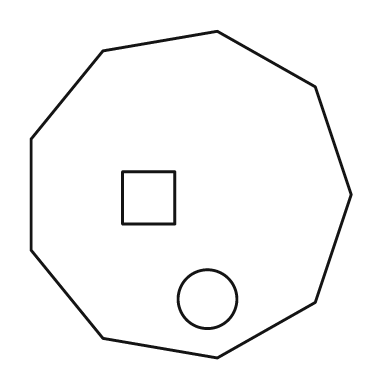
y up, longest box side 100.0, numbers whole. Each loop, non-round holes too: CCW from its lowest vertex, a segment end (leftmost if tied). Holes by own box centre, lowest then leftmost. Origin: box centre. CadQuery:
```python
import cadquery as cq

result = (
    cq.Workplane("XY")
    .moveTo(8.0, -50.0)
    .lineTo(38.0, -33.0)
    .lineTo(49.0, 0.0)
    .lineTo(38.0, 33.0)
    .lineTo(8.0, 50.0)
    .lineTo(-27.0, 44.0)
    .lineTo(-49.0, 17.0)
    .lineTo(-49.0, -17.0)
    .lineTo(-27.0, -44.0)
    .close()
    .moveTo(5.0, -32.0)
    .circle(9.0)
    .moveTo(-21.0, -9.0)
    .lineTo(-5.0, -9.0)
    .lineTo(-5.0, 7.0)
    .lineTo(-21.0, 7.0)
    .close()
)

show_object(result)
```